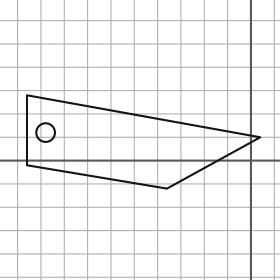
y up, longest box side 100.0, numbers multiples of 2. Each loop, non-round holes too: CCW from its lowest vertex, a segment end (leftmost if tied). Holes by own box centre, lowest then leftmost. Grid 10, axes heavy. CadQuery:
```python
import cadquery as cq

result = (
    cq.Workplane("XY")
    .moveTo(-36.0, -12.0)
    .lineTo(4.0, 10.0)
    .lineTo(-96.0, 28.0)
    .lineTo(-96.0, -2.0)
    .close()
    .moveTo(-88.0, 12.0)
    .circle(4.0)
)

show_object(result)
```